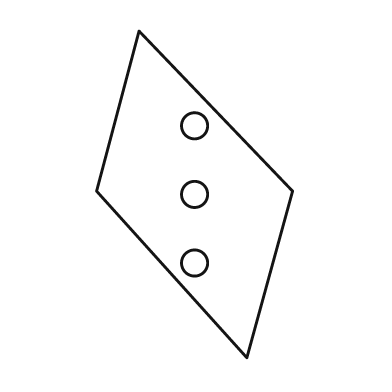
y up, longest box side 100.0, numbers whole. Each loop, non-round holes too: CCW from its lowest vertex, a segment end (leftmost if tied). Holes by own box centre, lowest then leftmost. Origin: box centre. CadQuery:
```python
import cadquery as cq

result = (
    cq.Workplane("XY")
    .moveTo(16.0, -50.0)
    .lineTo(30.0, 1.0)
    .lineTo(-17.0, 50.0)
    .lineTo(-30.0, 1.0)
    .close()
    .moveTo(0.0, -21.0)
    .circle(4.0)
    .moveTo(0.0, 0.0)
    .circle(4.0)
    .moveTo(0.0, 21.0)
    .circle(4.0)
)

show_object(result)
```